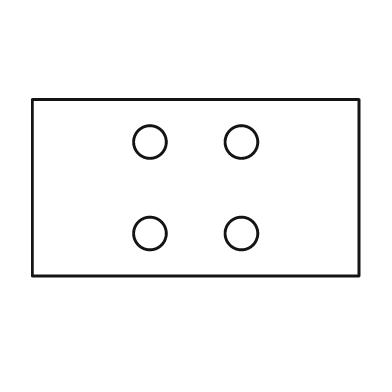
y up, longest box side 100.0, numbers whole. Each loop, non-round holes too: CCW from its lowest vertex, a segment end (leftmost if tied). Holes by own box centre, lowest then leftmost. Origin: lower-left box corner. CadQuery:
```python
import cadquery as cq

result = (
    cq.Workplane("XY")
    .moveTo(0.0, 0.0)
    .lineTo(100.0, 0.0)
    .lineTo(100.0, 54.0)
    .lineTo(0.0, 54.0)
    .close()
    .moveTo(36.0, 13.0)
    .circle(5.0)
    .moveTo(64.0, 13.0)
    .circle(5.0)
    .moveTo(36.0, 41.0)
    .circle(5.0)
    .moveTo(64.0, 41.0)
    .circle(5.0)
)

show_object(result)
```